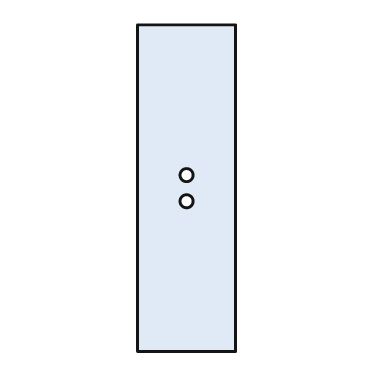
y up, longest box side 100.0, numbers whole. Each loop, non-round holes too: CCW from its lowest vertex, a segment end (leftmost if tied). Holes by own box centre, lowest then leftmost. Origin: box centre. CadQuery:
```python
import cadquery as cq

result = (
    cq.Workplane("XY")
    .moveTo(-15.0, -50.0)
    .lineTo(15.0, -50.0)
    .lineTo(15.0, 50.0)
    .lineTo(-15.0, 50.0)
    .close()
    .moveTo(0.0, -4.0)
    .circle(2.0)
    .moveTo(0.0, 4.0)
    .circle(2.0)
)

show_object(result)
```